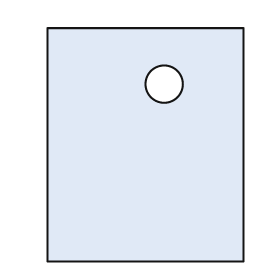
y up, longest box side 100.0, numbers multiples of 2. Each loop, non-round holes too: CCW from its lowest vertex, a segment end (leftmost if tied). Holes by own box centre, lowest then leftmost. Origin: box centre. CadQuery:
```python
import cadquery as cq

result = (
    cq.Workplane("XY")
    .moveTo(-42.0, -50.0)
    .lineTo(42.0, -50.0)
    .lineTo(42.0, 50.0)
    .lineTo(-42.0, 50.0)
    .close()
    .moveTo(8.0, 26.0)
    .circle(8.0)
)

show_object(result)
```